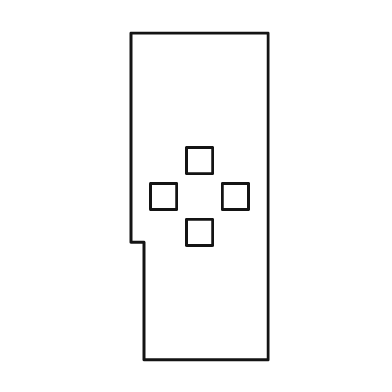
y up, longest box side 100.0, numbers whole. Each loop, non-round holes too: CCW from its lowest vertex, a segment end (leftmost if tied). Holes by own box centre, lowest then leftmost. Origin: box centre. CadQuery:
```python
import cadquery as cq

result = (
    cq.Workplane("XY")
    .moveTo(-17.0, -50.0)
    .lineTo(21.0, -50.0)
    .lineTo(21.0, 50.0)
    .lineTo(-21.0, 50.0)
    .lineTo(-21.0, -14.0)
    .lineTo(-17.0, -14.0)
    .close()
    .moveTo(-4.0, -15.0)
    .lineTo(4.0, -15.0)
    .lineTo(4.0, -7.0)
    .lineTo(-4.0, -7.0)
    .close()
    .moveTo(-15.0, -4.0)
    .lineTo(-7.0, -4.0)
    .lineTo(-7.0, 4.0)
    .lineTo(-15.0, 4.0)
    .close()
    .moveTo(7.0, -4.0)
    .lineTo(15.0, -4.0)
    .lineTo(15.0, 4.0)
    .lineTo(7.0, 4.0)
    .close()
    .moveTo(-4.0, 7.0)
    .lineTo(4.0, 7.0)
    .lineTo(4.0, 15.0)
    .lineTo(-4.0, 15.0)
    .close()
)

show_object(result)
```